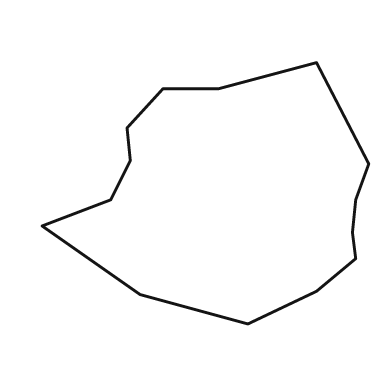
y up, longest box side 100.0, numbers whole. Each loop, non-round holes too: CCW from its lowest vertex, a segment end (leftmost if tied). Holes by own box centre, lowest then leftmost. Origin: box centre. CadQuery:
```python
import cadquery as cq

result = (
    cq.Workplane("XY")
    .moveTo(13.0, -40.0)
    .lineTo(34.0, -30.0)
    .lineTo(46.0, -20.0)
    .lineTo(45.0, -12.0)
    .lineTo(46.0, -2.0)
    .lineTo(50.0, 9.0)
    .lineTo(34.0, 40.0)
    .lineTo(4.0, 32.0)
    .lineTo(-13.0, 32.0)
    .lineTo(-24.0, 20.0)
    .lineTo(-23.0, 10.0)
    .lineTo(-29.0, -2.0)
    .lineTo(-50.0, -10.0)
    .lineTo(-20.0, -31.0)
    .close()
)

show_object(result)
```